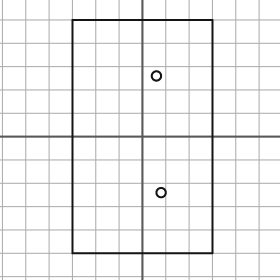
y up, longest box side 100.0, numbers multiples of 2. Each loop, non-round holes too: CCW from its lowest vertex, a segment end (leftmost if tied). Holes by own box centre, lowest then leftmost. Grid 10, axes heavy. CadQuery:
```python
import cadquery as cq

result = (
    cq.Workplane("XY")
    .moveTo(-30.0, -50.0)
    .lineTo(30.0, -50.0)
    .lineTo(30.0, 50.0)
    .lineTo(-30.0, 50.0)
    .close()
    .moveTo(8.0, -24.0)
    .circle(2.0)
    .moveTo(6.0, 26.0)
    .circle(2.0)
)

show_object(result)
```